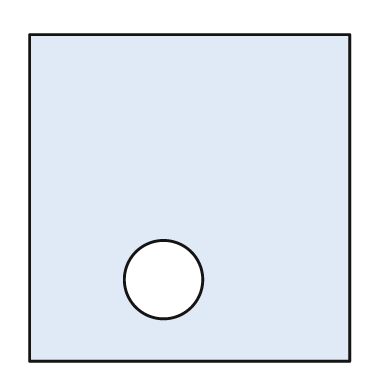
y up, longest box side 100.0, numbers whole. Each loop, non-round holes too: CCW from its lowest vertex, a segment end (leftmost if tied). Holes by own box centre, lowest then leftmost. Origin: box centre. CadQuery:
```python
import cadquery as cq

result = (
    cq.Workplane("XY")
    .moveTo(-49.0, -50.0)
    .lineTo(49.0, -50.0)
    .lineTo(49.0, 50.0)
    .lineTo(-49.0, 50.0)
    .close()
    .moveTo(-8.0, -25.0)
    .circle(12.0)
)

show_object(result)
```